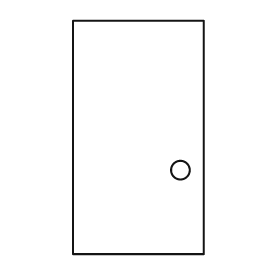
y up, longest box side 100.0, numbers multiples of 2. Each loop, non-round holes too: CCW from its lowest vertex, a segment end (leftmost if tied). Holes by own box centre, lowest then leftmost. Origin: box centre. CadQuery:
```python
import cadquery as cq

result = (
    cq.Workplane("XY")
    .moveTo(-28.0, -50.0)
    .lineTo(28.0, -50.0)
    .lineTo(28.0, 50.0)
    .lineTo(-28.0, 50.0)
    .close()
    .moveTo(18.0, -14.0)
    .circle(4.0)
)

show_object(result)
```